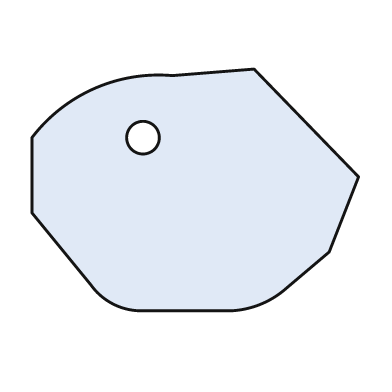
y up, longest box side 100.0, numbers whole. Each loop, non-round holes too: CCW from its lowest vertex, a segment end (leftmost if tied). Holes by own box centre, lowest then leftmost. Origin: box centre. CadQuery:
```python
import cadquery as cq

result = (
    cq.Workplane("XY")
    .moveTo(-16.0, -37.0)
    .lineTo(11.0, -37.0)
    .threePointArc((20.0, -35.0), (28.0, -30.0))
    .lineTo(41.0, -19.0)
    .lineTo(50.0, 4.0)
    .lineTo(18.0, 37.0)
    .lineTo(-7.0, 35.0)
    .threePointArc((-31.0, 31.0), (-50.0, 16.0))
    .lineTo(-50.0, -7.0)
    .lineTo(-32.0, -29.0)
    .threePointArc((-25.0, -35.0), (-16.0, -37.0))
    .close()
    .moveTo(-16.0, 16.0)
    .circle(5.0)
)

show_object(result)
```